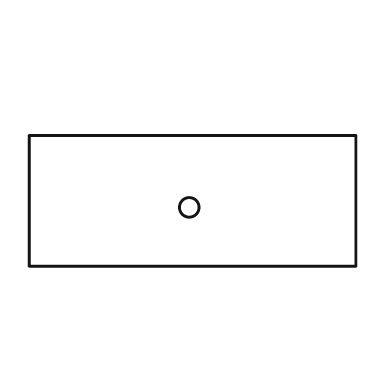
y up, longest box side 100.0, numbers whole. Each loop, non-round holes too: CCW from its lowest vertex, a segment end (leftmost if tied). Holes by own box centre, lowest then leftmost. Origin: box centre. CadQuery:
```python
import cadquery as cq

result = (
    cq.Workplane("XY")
    .moveTo(-50.0, -20.0)
    .lineTo(50.0, -20.0)
    .lineTo(50.0, 20.0)
    .lineTo(-50.0, 20.0)
    .close()
    .moveTo(-1.0, -2.0)
    .circle(3.0)
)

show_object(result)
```